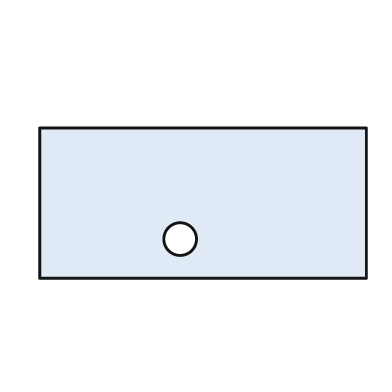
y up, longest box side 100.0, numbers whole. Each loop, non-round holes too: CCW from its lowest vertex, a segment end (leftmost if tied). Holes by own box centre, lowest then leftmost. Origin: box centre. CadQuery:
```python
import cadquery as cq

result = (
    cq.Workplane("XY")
    .moveTo(-50.0, -23.0)
    .lineTo(50.0, -23.0)
    .lineTo(50.0, 23.0)
    .lineTo(-50.0, 23.0)
    .close()
    .moveTo(-7.0, -11.0)
    .circle(5.0)
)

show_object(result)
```